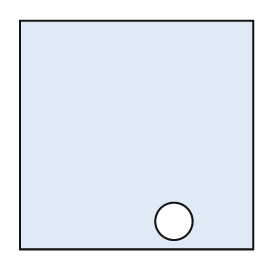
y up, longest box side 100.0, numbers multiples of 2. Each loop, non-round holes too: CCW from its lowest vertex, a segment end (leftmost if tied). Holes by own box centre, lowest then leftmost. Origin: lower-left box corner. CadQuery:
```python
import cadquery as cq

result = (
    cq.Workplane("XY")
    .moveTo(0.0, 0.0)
    .lineTo(100.0, 0.0)
    .lineTo(100.0, 98.0)
    .lineTo(0.0, 98.0)
    .close()
    .moveTo(66.0, 12.0)
    .circle(8.0)
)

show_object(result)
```